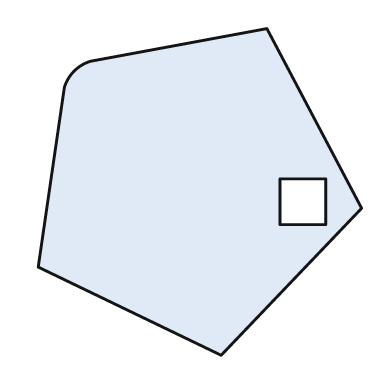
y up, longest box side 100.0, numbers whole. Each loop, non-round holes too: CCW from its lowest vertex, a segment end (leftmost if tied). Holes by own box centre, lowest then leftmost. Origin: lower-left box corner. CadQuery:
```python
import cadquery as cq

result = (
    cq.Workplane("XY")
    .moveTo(56.0, 0.0)
    .lineTo(99.0, 45.0)
    .lineTo(70.0, 100.0)
    .lineTo(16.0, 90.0)
    .threePointArc((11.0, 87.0), (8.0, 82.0))
    .lineTo(0.0, 27.0)
    .close()
    .moveTo(74.0, 40.0)
    .lineTo(88.0, 40.0)
    .lineTo(88.0, 54.0)
    .lineTo(74.0, 54.0)
    .close()
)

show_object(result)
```